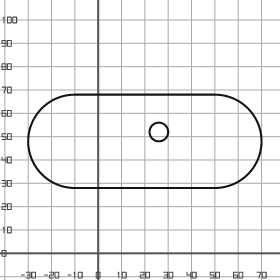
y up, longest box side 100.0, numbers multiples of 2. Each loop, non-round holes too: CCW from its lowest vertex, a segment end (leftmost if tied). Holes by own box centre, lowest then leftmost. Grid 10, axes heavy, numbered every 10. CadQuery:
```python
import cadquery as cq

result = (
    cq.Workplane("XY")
    .moveTo(-10.0, 28.0)
    .lineTo(50.0, 28.0)
    .threePointArc((70.0, 48.0), (50.0, 68.0))
    .lineTo(-10.0, 68.0)
    .threePointArc((-30.0, 48.0), (-10.0, 28.0))
    .close()
    .moveTo(26.0, 52.0)
    .circle(4.0)
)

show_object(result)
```